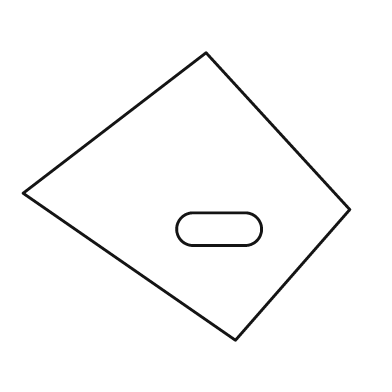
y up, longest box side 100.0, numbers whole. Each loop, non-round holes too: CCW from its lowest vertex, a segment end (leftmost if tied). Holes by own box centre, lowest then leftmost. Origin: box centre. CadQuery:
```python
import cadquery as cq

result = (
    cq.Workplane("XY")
    .moveTo(15.0, -44.0)
    .lineTo(50.0, -4.0)
    .lineTo(6.0, 44.0)
    .lineTo(-50.0, 1.0)
    .close()
    .moveTo(2.0, -15.0)
    .lineTo(18.0, -15.0)
    .threePointArc((23.0, -10.0), (18.0, -5.0))
    .lineTo(2.0, -5.0)
    .threePointArc((-3.0, -10.0), (2.0, -15.0))
    .close()
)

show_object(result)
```